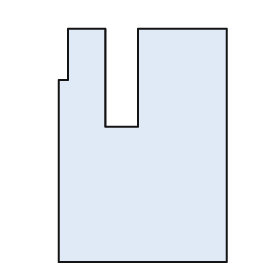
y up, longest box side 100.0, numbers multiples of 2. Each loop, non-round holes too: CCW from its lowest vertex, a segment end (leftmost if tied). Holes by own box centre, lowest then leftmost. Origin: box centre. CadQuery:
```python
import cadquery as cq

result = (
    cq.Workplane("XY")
    .moveTo(-36.0, -50.0)
    .lineTo(36.0, -50.0)
    .lineTo(36.0, 50.0)
    .lineTo(-2.0, 50.0)
    .lineTo(-2.0, 8.0)
    .lineTo(-16.0, 8.0)
    .lineTo(-16.0, 50.0)
    .lineTo(-32.0, 50.0)
    .lineTo(-32.0, 28.0)
    .lineTo(-36.0, 28.0)
    .close()
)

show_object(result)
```